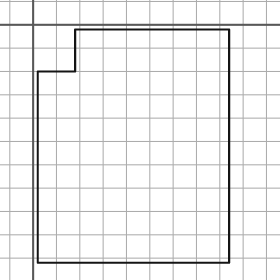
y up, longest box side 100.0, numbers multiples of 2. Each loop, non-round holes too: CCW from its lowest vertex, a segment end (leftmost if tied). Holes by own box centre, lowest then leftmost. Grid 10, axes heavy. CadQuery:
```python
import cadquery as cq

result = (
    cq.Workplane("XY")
    .moveTo(2.0, -102.0)
    .lineTo(84.0, -102.0)
    .lineTo(84.0, -2.0)
    .lineTo(18.0, -2.0)
    .lineTo(18.0, -20.0)
    .lineTo(2.0, -20.0)
    .close()
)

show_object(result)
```